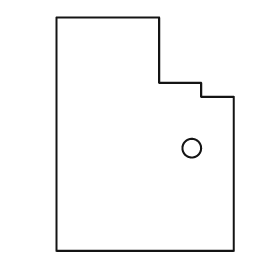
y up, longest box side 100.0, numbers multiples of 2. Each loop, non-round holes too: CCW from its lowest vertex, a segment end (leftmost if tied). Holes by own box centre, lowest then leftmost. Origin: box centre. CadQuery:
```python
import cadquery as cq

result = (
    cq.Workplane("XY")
    .moveTo(-38.0, -50.0)
    .lineTo(38.0, -50.0)
    .lineTo(38.0, 16.0)
    .lineTo(24.0, 16.0)
    .lineTo(24.0, 22.0)
    .lineTo(6.0, 22.0)
    .lineTo(6.0, 50.0)
    .lineTo(-38.0, 50.0)
    .close()
    .moveTo(20.0, -6.0)
    .circle(4.0)
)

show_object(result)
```